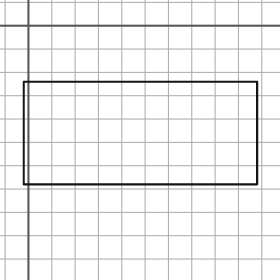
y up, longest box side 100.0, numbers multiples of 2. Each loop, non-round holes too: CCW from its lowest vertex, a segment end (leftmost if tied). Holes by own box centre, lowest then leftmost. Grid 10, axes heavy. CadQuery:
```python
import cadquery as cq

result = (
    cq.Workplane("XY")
    .moveTo(-2.0, -68.0)
    .lineTo(98.0, -68.0)
    .lineTo(98.0, -24.0)
    .lineTo(-2.0, -24.0)
    .close()
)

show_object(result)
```